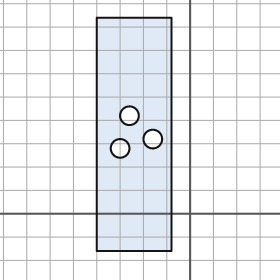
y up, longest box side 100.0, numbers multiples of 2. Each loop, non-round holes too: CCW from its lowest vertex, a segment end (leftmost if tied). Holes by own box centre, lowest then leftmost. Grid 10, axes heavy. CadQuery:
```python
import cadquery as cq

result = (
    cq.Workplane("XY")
    .moveTo(-40.0, -16.0)
    .lineTo(-8.0, -16.0)
    .lineTo(-8.0, 84.0)
    .lineTo(-40.0, 84.0)
    .close()
    .moveTo(-30.0, 28.0)
    .circle(4.0)
    .moveTo(-16.0, 32.0)
    .circle(4.0)
    .moveTo(-26.0, 42.0)
    .circle(4.0)
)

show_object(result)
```